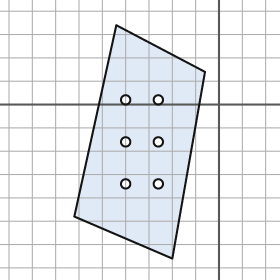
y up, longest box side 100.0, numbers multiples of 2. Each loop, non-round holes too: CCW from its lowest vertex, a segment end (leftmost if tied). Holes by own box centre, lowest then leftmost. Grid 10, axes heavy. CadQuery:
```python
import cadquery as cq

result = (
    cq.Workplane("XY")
    .moveTo(-20.0, -66.0)
    .lineTo(-6.0, 14.0)
    .lineTo(-44.0, 34.0)
    .lineTo(-62.0, -48.0)
    .close()
    .moveTo(-40.0, -34.0)
    .circle(2.0)
    .moveTo(-26.0, -34.0)
    .circle(2.0)
    .moveTo(-40.0, -16.0)
    .circle(2.0)
    .moveTo(-26.0, -16.0)
    .circle(2.0)
    .moveTo(-40.0, 2.0)
    .circle(2.0)
    .moveTo(-26.0, 2.0)
    .circle(2.0)
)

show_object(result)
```